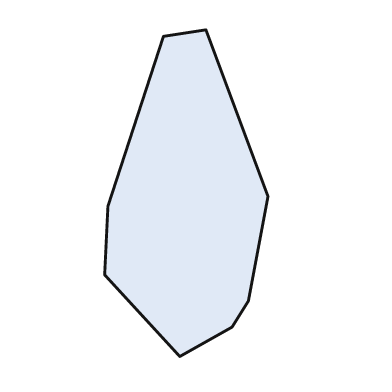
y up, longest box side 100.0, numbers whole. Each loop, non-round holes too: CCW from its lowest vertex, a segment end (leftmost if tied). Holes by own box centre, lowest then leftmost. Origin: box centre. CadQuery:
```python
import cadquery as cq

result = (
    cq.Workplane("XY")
    .moveTo(-2.0, -50.0)
    .lineTo(14.0, -41.0)
    .lineTo(19.0, -33.0)
    .lineTo(25.0, -1.0)
    .lineTo(6.0, 50.0)
    .lineTo(-7.0, 48.0)
    .lineTo(-24.0, -4.0)
    .lineTo(-25.0, -25.0)
    .close()
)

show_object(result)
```